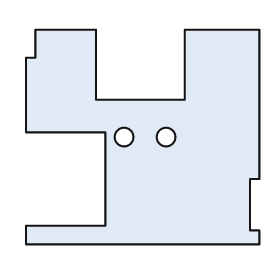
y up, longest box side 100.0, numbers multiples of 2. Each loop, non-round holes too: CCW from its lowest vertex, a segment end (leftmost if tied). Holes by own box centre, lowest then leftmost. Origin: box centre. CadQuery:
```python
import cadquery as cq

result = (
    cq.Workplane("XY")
    .moveTo(-50.0, -46.0)
    .lineTo(50.0, -46.0)
    .lineTo(50.0, -40.0)
    .lineTo(46.0, -40.0)
    .lineTo(46.0, -18.0)
    .lineTo(50.0, -18.0)
    .lineTo(50.0, 46.0)
    .lineTo(18.0, 46.0)
    .lineTo(18.0, 16.0)
    .lineTo(-20.0, 16.0)
    .lineTo(-20.0, 46.0)
    .lineTo(-46.0, 46.0)
    .lineTo(-46.0, 34.0)
    .lineTo(-50.0, 34.0)
    .lineTo(-50.0, 2.0)
    .lineTo(-16.0, 2.0)
    .lineTo(-16.0, -38.0)
    .lineTo(-50.0, -38.0)
    .close()
    .moveTo(-8.0, 0.0)
    .circle(4.0)
    .moveTo(10.0, 0.0)
    .circle(4.0)
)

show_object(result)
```